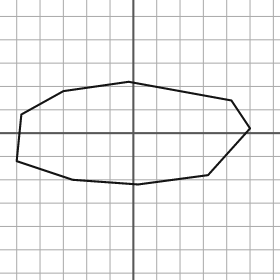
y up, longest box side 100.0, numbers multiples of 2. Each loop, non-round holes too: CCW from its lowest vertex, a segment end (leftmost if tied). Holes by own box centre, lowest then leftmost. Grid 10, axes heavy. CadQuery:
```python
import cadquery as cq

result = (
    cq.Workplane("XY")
    .moveTo(2.0, -22.0)
    .lineTo(32.0, -18.0)
    .lineTo(50.0, 2.0)
    .lineTo(42.0, 14.0)
    .lineTo(-2.0, 22.0)
    .lineTo(-30.0, 18.0)
    .lineTo(-48.0, 8.0)
    .lineTo(-50.0, -12.0)
    .lineTo(-26.0, -20.0)
    .close()
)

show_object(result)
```